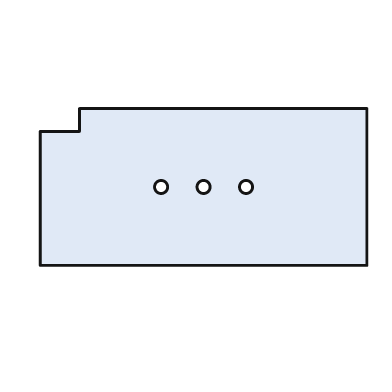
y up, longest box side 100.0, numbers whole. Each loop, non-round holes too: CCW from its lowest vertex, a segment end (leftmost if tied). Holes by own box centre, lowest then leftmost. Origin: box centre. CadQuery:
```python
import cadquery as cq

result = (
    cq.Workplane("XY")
    .moveTo(-50.0, -24.0)
    .lineTo(50.0, -24.0)
    .lineTo(50.0, 24.0)
    .lineTo(-38.0, 24.0)
    .lineTo(-38.0, 17.0)
    .lineTo(-50.0, 17.0)
    .close()
    .moveTo(-13.0, 0.0)
    .circle(2.0)
    .moveTo(0.0, 0.0)
    .circle(2.0)
    .moveTo(13.0, 0.0)
    .circle(2.0)
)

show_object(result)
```